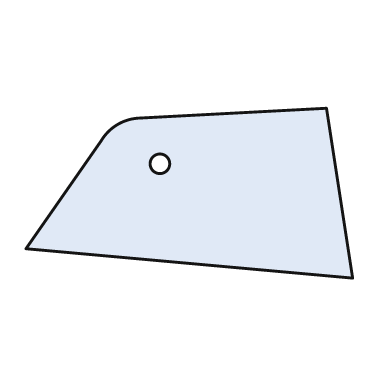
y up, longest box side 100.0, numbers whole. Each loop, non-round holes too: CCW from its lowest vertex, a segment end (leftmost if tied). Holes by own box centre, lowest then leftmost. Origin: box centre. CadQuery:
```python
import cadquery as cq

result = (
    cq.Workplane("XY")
    .moveTo(50.0, -26.0)
    .lineTo(42.0, 26.0)
    .lineTo(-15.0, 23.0)
    .threePointArc((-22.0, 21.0), (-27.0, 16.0))
    .lineTo(-50.0, -17.0)
    .close()
    .moveTo(-9.0, 9.0)
    .circle(3.0)
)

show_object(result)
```